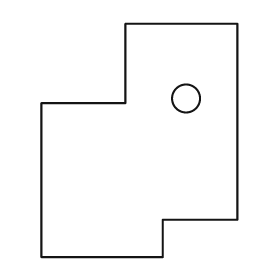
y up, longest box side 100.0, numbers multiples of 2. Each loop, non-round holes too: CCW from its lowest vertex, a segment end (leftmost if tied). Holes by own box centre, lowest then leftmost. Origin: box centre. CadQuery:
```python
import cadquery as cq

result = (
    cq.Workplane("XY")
    .moveTo(-42.0, -50.0)
    .lineTo(10.0, -50.0)
    .lineTo(10.0, -34.0)
    .lineTo(42.0, -34.0)
    .lineTo(42.0, 50.0)
    .lineTo(-6.0, 50.0)
    .lineTo(-6.0, 16.0)
    .lineTo(-42.0, 16.0)
    .close()
    .moveTo(20.0, 18.0)
    .circle(6.0)
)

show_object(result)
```